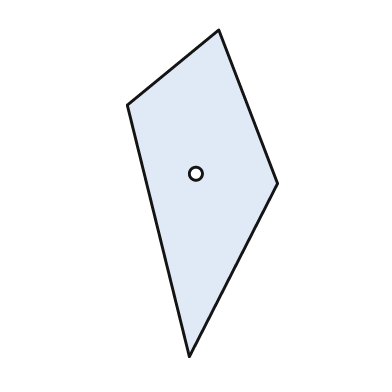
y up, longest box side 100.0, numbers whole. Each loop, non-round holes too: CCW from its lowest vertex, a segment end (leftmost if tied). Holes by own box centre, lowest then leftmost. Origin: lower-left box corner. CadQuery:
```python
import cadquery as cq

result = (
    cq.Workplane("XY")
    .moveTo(19.0, 0.0)
    .lineTo(46.0, 53.0)
    .lineTo(28.0, 100.0)
    .lineTo(0.0, 77.0)
    .close()
    .moveTo(21.0, 56.0)
    .circle(2.0)
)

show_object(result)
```